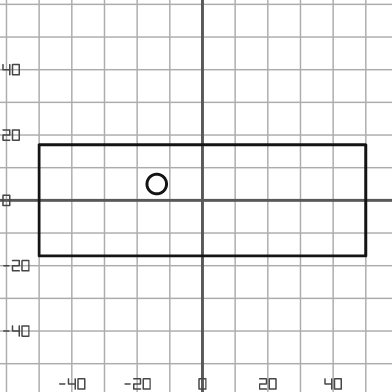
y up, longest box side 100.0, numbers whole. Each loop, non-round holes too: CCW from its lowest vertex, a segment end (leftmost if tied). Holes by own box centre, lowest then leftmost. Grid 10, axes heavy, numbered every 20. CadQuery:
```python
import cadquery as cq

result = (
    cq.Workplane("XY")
    .moveTo(-50.0, -17.0)
    .lineTo(50.0, -17.0)
    .lineTo(50.0, 17.0)
    .lineTo(-50.0, 17.0)
    .close()
    .moveTo(-14.0, 5.0)
    .circle(3.0)
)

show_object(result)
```